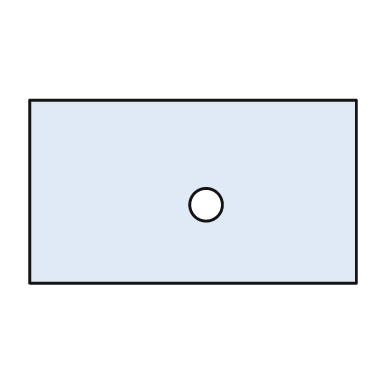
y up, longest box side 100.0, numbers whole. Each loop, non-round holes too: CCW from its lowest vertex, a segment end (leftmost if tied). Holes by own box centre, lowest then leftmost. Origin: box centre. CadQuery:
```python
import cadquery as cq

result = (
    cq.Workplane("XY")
    .moveTo(-50.0, -28.0)
    .lineTo(50.0, -28.0)
    .lineTo(50.0, 28.0)
    .lineTo(-50.0, 28.0)
    .close()
    .moveTo(4.0, -4.0)
    .circle(5.0)
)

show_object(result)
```